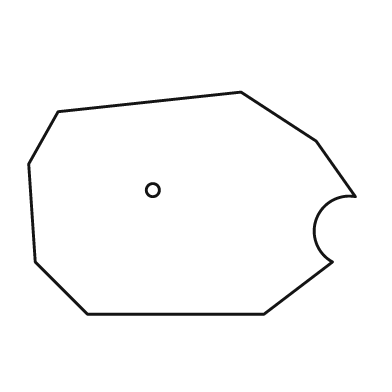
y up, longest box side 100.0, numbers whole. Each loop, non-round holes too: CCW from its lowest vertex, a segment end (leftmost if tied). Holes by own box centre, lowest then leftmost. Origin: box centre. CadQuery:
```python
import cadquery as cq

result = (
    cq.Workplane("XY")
    .moveTo(-32.0, -34.0)
    .lineTo(22.0, -34.0)
    .lineTo(43.0, -18.0)
    .threePointArc((38.0, -5.0), (50.0, 2.0))
    .lineTo(38.0, 19.0)
    .lineTo(15.0, 34.0)
    .lineTo(-41.0, 28.0)
    .lineTo(-50.0, 12.0)
    .lineTo(-48.0, -18.0)
    .close()
    .moveTo(-12.0, 4.0)
    .circle(2.0)
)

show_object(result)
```